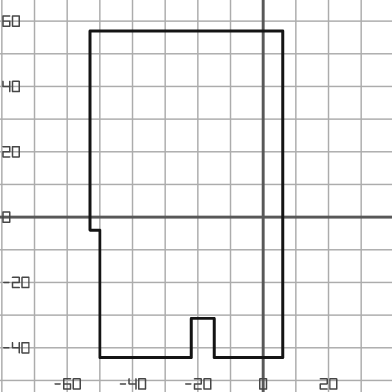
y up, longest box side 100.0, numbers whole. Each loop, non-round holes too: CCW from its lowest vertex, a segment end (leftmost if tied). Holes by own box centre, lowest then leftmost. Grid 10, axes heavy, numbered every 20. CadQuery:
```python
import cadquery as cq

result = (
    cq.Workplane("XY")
    .moveTo(-50.0, -43.0)
    .lineTo(-22.0, -43.0)
    .lineTo(-22.0, -31.0)
    .lineTo(-15.0, -31.0)
    .lineTo(-15.0, -43.0)
    .lineTo(6.0, -43.0)
    .lineTo(6.0, 57.0)
    .lineTo(-53.0, 57.0)
    .lineTo(-53.0, -4.0)
    .lineTo(-50.0, -4.0)
    .close()
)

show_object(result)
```